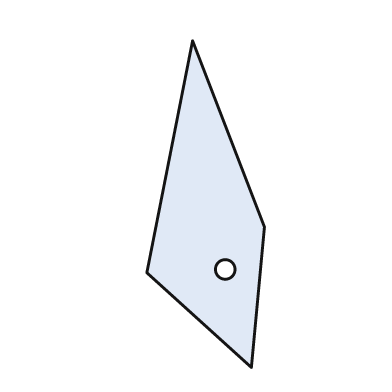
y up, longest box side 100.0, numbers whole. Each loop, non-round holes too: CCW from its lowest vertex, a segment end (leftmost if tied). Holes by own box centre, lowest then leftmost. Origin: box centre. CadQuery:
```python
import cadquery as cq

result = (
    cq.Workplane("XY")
    .moveTo(14.0, -50.0)
    .lineTo(18.0, -7.0)
    .lineTo(-4.0, 50.0)
    .lineTo(-18.0, -21.0)
    .close()
    .moveTo(6.0, -20.0)
    .circle(3.0)
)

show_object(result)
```